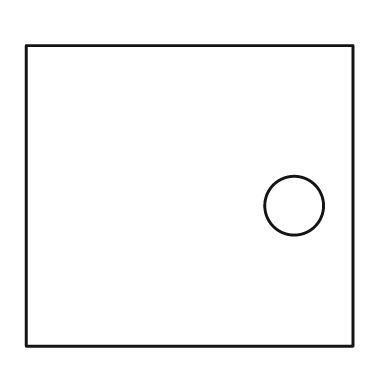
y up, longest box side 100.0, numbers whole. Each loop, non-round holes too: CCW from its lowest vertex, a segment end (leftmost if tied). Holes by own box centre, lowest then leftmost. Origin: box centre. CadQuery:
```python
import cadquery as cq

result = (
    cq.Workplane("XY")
    .moveTo(-50.0, -46.0)
    .lineTo(50.0, -46.0)
    .lineTo(50.0, 46.0)
    .lineTo(-50.0, 46.0)
    .close()
    .moveTo(32.0, -3.0)
    .circle(9.0)
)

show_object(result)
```